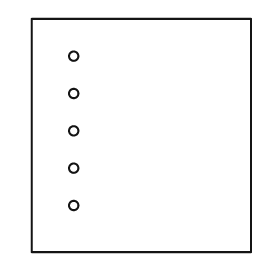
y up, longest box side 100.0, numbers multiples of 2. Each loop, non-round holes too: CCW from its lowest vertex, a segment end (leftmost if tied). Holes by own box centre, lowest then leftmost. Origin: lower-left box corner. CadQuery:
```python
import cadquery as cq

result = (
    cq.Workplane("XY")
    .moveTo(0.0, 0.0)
    .lineTo(94.0, 0.0)
    .lineTo(94.0, 100.0)
    .lineTo(0.0, 100.0)
    .close()
    .moveTo(18.0, 20.0)
    .circle(2.0)
    .moveTo(18.0, 36.0)
    .circle(2.0)
    .moveTo(18.0, 52.0)
    .circle(2.0)
    .moveTo(18.0, 68.0)
    .circle(2.0)
    .moveTo(18.0, 84.0)
    .circle(2.0)
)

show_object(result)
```